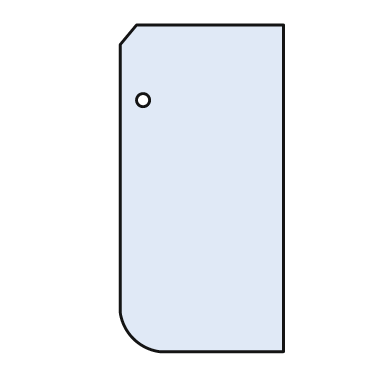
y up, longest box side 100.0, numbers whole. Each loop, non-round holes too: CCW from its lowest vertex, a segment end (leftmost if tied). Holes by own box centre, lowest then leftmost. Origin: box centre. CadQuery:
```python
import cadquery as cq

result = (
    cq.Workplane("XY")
    .moveTo(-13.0, -50.0)
    .lineTo(25.0, -50.0)
    .lineTo(25.0, 50.0)
    .lineTo(-20.0, 50.0)
    .lineTo(-25.0, 44.0)
    .lineTo(-25.0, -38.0)
    .threePointArc((-21.0, -46.0), (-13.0, -50.0))
    .close()
    .moveTo(-18.0, 27.0)
    .circle(2.0)
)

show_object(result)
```